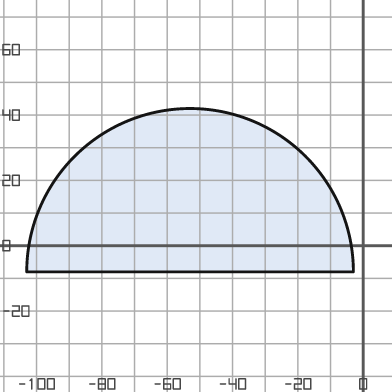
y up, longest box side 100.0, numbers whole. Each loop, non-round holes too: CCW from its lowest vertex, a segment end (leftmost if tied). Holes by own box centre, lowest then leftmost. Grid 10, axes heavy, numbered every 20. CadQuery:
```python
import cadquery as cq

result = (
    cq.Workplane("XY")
    .moveTo(-103.0, -8.0)
    .lineTo(-3.0, -8.0)
    .threePointArc((-53.0, 42.0), (-103.0, -8.0))
    .close()
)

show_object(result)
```